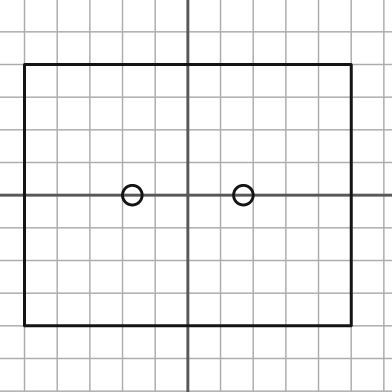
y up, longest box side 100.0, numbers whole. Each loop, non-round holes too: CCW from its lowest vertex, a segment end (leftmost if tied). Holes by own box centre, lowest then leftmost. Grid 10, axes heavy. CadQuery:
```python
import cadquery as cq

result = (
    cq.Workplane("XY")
    .moveTo(-50.0, -40.0)
    .lineTo(50.0, -40.0)
    .lineTo(50.0, 40.0)
    .lineTo(-50.0, 40.0)
    .close()
    .moveTo(-17.0, 0.0)
    .circle(3.0)
    .moveTo(17.0, 0.0)
    .circle(3.0)
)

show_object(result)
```